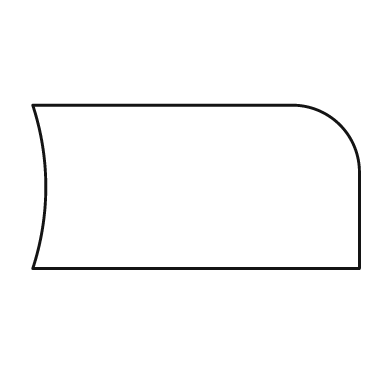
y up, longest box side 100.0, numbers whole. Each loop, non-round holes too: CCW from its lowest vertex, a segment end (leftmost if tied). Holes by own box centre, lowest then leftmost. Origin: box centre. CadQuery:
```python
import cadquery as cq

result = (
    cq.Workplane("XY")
    .moveTo(-50.0, -25.0)
    .lineTo(50.0, -25.0)
    .lineTo(50.0, 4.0)
    .threePointArc((44.0, 19.0), (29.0, 25.0))
    .lineTo(-50.0, 25.0)
    .threePointArc((-46.0, 0.0), (-50.0, -25.0))
    .close()
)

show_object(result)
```